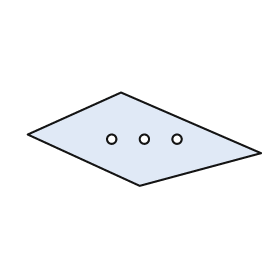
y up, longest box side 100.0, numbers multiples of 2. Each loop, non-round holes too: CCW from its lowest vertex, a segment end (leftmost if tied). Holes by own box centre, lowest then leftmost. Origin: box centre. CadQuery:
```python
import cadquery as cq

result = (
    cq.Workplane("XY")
    .moveTo(-2.0, -20.0)
    .lineTo(50.0, -6.0)
    .lineTo(-10.0, 20.0)
    .lineTo(-50.0, 2.0)
    .close()
    .moveTo(-14.0, 0.0)
    .circle(2.0)
    .moveTo(0.0, 0.0)
    .circle(2.0)
    .moveTo(14.0, 0.0)
    .circle(2.0)
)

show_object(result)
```